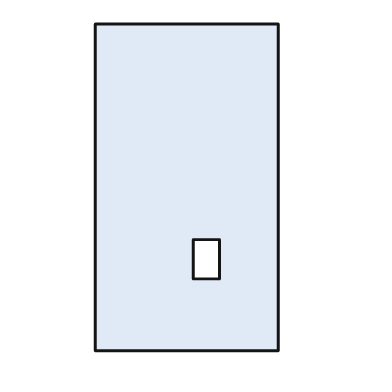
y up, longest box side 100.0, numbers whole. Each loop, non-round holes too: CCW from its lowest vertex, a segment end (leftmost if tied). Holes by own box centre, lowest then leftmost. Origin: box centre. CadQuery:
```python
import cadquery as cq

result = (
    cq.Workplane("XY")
    .moveTo(-28.0, -50.0)
    .lineTo(28.0, -50.0)
    .lineTo(28.0, 50.0)
    .lineTo(-28.0, 50.0)
    .close()
    .moveTo(2.0, -28.0)
    .lineTo(10.0, -28.0)
    .lineTo(10.0, -16.0)
    .lineTo(2.0, -16.0)
    .close()
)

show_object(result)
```